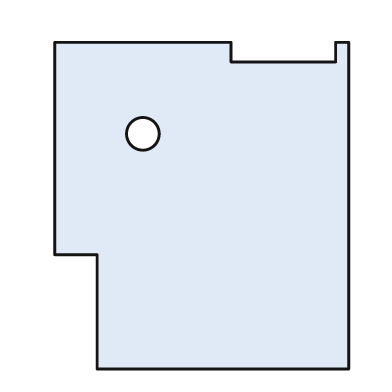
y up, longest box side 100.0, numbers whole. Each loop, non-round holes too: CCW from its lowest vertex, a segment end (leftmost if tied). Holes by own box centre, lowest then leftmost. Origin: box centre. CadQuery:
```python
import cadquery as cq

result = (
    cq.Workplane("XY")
    .moveTo(-32.0, -50.0)
    .lineTo(45.0, -50.0)
    .lineTo(45.0, 50.0)
    .lineTo(41.0, 50.0)
    .lineTo(41.0, 44.0)
    .lineTo(9.0, 44.0)
    .lineTo(9.0, 50.0)
    .lineTo(-45.0, 50.0)
    .lineTo(-45.0, -15.0)
    .lineTo(-32.0, -15.0)
    .close()
    .moveTo(-18.0, 22.0)
    .circle(5.0)
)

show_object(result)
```